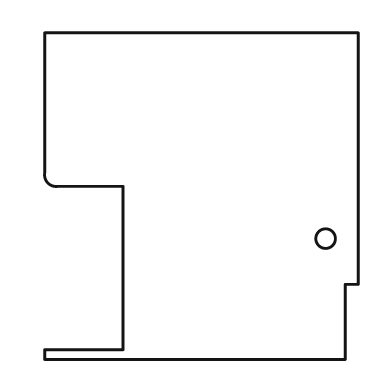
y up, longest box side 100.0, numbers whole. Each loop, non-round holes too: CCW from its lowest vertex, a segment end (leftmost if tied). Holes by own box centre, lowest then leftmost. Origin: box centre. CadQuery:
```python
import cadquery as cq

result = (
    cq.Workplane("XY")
    .moveTo(-48.0, -50.0)
    .lineTo(44.0, -50.0)
    .lineTo(44.0, -27.0)
    .lineTo(48.0, -27.0)
    .lineTo(48.0, 50.0)
    .lineTo(-48.0, 50.0)
    .lineTo(-48.0, 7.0)
    .threePointArc((-47.0, 4.0), (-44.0, 3.0))
    .lineTo(-24.0, 3.0)
    .lineTo(-24.0, -47.0)
    .lineTo(-48.0, -47.0)
    .close()
    .moveTo(38.0, -13.0)
    .circle(3.0)
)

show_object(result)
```